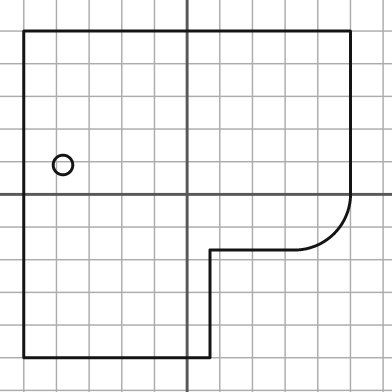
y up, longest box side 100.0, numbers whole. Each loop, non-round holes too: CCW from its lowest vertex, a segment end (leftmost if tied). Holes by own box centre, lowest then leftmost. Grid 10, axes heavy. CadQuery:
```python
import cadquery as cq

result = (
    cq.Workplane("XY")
    .moveTo(-50.0, -50.0)
    .lineTo(7.0, -50.0)
    .lineTo(7.0, -17.0)
    .lineTo(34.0, -17.0)
    .threePointArc((45.0, -12.0), (50.0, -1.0))
    .lineTo(50.0, 50.0)
    .lineTo(-50.0, 50.0)
    .close()
    .moveTo(-38.0, 9.0)
    .circle(3.0)
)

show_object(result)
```